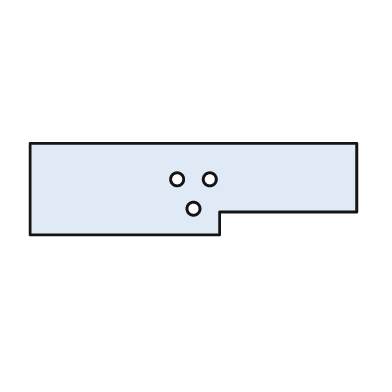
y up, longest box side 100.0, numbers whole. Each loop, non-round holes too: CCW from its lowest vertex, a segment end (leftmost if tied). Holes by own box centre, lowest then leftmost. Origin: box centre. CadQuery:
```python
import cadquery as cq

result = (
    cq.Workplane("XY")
    .moveTo(-50.0, -14.0)
    .lineTo(8.0, -14.0)
    .lineTo(8.0, -7.0)
    .lineTo(50.0, -7.0)
    .lineTo(50.0, 14.0)
    .lineTo(-50.0, 14.0)
    .close()
    .moveTo(0.0, -6.0)
    .circle(2.0)
    .moveTo(-5.0, 3.0)
    .circle(2.0)
    .moveTo(5.0, 3.0)
    .circle(2.0)
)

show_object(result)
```